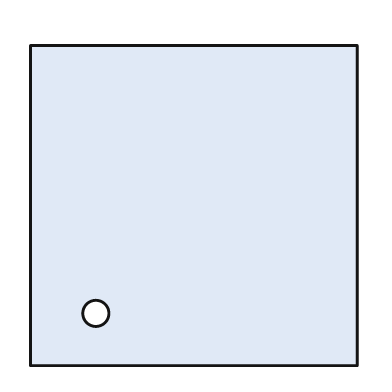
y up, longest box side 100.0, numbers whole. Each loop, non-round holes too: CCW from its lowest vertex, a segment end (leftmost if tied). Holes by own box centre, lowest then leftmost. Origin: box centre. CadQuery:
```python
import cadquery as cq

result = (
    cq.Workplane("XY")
    .moveTo(-50.0, -49.0)
    .lineTo(50.0, -49.0)
    .lineTo(50.0, 49.0)
    .lineTo(-50.0, 49.0)
    .close()
    .moveTo(-30.0, -33.0)
    .circle(4.0)
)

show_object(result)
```